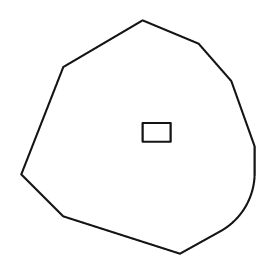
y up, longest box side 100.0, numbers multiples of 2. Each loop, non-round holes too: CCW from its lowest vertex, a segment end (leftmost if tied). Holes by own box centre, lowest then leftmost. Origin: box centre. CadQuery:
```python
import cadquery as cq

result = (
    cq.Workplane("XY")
    .moveTo(18.0, -50.0)
    .lineTo(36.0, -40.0)
    .threePointArc((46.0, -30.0), (50.0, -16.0))
    .lineTo(50.0, -4.0)
    .lineTo(40.0, 24.0)
    .lineTo(26.0, 40.0)
    .lineTo(2.0, 50.0)
    .lineTo(-32.0, 30.0)
    .lineTo(-50.0, -16.0)
    .lineTo(-32.0, -34.0)
    .close()
    .moveTo(2.0, -2.0)
    .lineTo(14.0, -2.0)
    .lineTo(14.0, 6.0)
    .lineTo(2.0, 6.0)
    .close()
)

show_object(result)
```